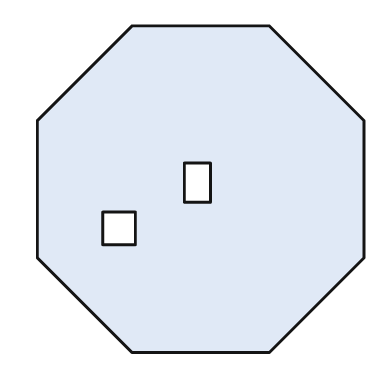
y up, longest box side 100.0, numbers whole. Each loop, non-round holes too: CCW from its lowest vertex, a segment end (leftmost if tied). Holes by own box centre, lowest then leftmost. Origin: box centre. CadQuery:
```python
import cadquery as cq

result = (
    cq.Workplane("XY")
    .moveTo(-21.0, -50.0)
    .lineTo(21.0, -50.0)
    .lineTo(50.0, -21.0)
    .lineTo(50.0, 21.0)
    .lineTo(21.0, 50.0)
    .lineTo(-21.0, 50.0)
    .lineTo(-50.0, 21.0)
    .lineTo(-50.0, -21.0)
    .close()
    .moveTo(-30.0, -17.0)
    .lineTo(-20.0, -17.0)
    .lineTo(-20.0, -7.0)
    .lineTo(-30.0, -7.0)
    .close()
    .moveTo(-5.0, -4.0)
    .lineTo(3.0, -4.0)
    .lineTo(3.0, 8.0)
    .lineTo(-5.0, 8.0)
    .close()
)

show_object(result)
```